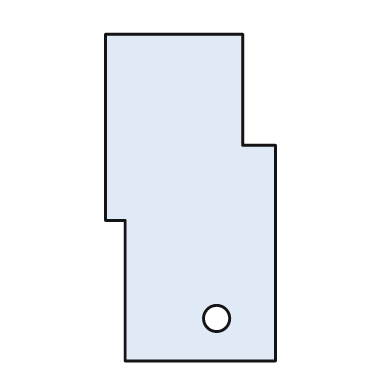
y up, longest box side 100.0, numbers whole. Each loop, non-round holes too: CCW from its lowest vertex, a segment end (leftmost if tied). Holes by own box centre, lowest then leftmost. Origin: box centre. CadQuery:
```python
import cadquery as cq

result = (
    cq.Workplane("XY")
    .moveTo(-20.0, -50.0)
    .lineTo(26.0, -50.0)
    .lineTo(26.0, 16.0)
    .lineTo(16.0, 16.0)
    .lineTo(16.0, 50.0)
    .lineTo(-26.0, 50.0)
    .lineTo(-26.0, -7.0)
    .lineTo(-20.0, -7.0)
    .close()
    .moveTo(8.0, -37.0)
    .circle(4.0)
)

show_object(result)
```